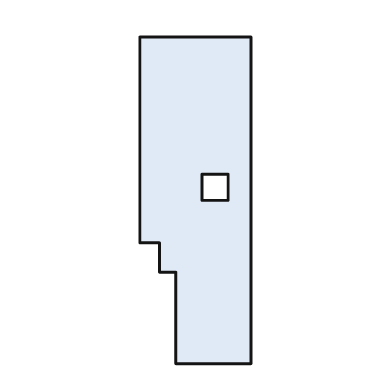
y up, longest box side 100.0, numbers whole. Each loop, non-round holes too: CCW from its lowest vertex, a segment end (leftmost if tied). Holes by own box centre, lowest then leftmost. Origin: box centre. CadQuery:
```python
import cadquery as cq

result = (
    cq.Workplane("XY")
    .moveTo(-6.0, -50.0)
    .lineTo(17.0, -50.0)
    .lineTo(17.0, 50.0)
    .lineTo(-17.0, 50.0)
    .lineTo(-17.0, -13.0)
    .lineTo(-11.0, -13.0)
    .lineTo(-11.0, -22.0)
    .lineTo(-6.0, -22.0)
    .close()
    .moveTo(2.0, 0.0)
    .lineTo(10.0, 0.0)
    .lineTo(10.0, 8.0)
    .lineTo(2.0, 8.0)
    .close()
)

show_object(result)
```